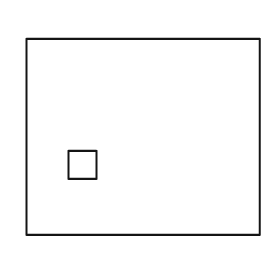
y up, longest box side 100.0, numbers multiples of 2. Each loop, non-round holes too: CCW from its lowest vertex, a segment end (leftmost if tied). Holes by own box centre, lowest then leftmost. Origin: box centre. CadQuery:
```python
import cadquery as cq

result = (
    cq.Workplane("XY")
    .moveTo(-50.0, -42.0)
    .lineTo(50.0, -42.0)
    .lineTo(50.0, 42.0)
    .lineTo(-50.0, 42.0)
    .close()
    .moveTo(-32.0, -18.0)
    .lineTo(-20.0, -18.0)
    .lineTo(-20.0, -6.0)
    .lineTo(-32.0, -6.0)
    .close()
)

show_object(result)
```